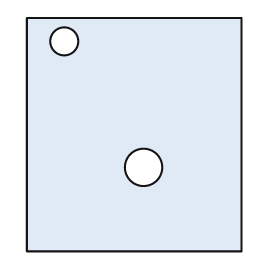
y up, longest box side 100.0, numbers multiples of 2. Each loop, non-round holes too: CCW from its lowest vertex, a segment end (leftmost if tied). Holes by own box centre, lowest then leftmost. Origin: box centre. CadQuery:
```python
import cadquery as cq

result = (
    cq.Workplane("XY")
    .moveTo(-46.0, -50.0)
    .lineTo(46.0, -50.0)
    .lineTo(46.0, 50.0)
    .lineTo(-46.0, 50.0)
    .close()
    .moveTo(4.0, -14.0)
    .circle(8.0)
    .moveTo(-30.0, 40.0)
    .circle(6.0)
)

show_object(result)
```